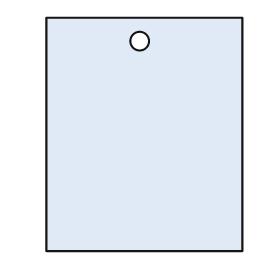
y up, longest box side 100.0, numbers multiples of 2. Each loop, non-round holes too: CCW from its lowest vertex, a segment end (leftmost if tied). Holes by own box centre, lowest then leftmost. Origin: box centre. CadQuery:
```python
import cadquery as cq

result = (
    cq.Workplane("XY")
    .moveTo(-42.0, -50.0)
    .lineTo(42.0, -50.0)
    .lineTo(42.0, 50.0)
    .lineTo(-42.0, 50.0)
    .close()
    .moveTo(-2.0, 40.0)
    .circle(4.0)
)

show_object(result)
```